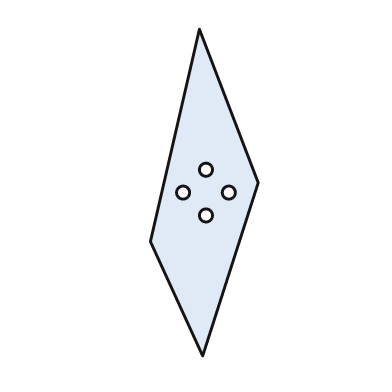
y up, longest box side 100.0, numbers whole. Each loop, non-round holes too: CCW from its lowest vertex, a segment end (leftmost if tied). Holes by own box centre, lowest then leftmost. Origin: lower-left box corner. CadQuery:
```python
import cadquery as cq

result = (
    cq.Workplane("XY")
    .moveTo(16.0, 0.0)
    .lineTo(33.0, 53.0)
    .lineTo(15.0, 100.0)
    .lineTo(0.0, 35.0)
    .close()
    .moveTo(17.0, 43.0)
    .circle(2.0)
    .moveTo(10.0, 50.0)
    .circle(2.0)
    .moveTo(24.0, 50.0)
    .circle(2.0)
    .moveTo(17.0, 57.0)
    .circle(2.0)
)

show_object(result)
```